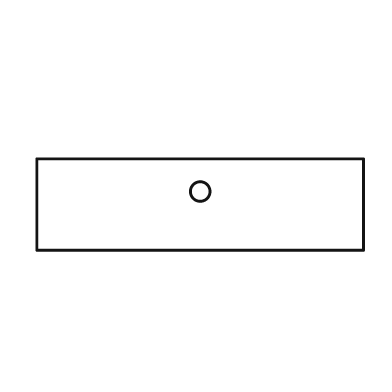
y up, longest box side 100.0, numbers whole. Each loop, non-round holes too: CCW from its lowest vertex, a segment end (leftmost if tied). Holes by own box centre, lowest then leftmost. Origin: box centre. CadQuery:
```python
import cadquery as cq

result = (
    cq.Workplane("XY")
    .moveTo(-50.0, -14.0)
    .lineTo(50.0, -14.0)
    .lineTo(50.0, 14.0)
    .lineTo(-50.0, 14.0)
    .close()
    .moveTo(0.0, 4.0)
    .circle(3.0)
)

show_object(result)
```